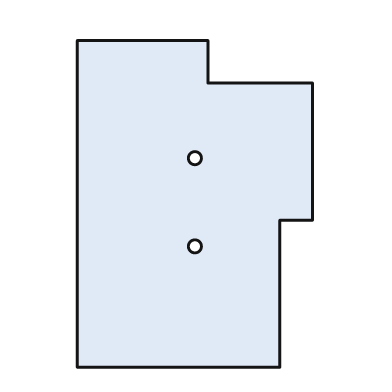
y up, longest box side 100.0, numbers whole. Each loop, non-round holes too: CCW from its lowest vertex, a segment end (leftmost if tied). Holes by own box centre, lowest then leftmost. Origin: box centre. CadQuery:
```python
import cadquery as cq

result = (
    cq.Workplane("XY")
    .moveTo(-36.0, -50.0)
    .lineTo(26.0, -50.0)
    .lineTo(26.0, -5.0)
    .lineTo(36.0, -5.0)
    .lineTo(36.0, 37.0)
    .lineTo(4.0, 37.0)
    .lineTo(4.0, 50.0)
    .lineTo(-36.0, 50.0)
    .close()
    .moveTo(0.0, -13.0)
    .circle(2.0)
    .moveTo(0.0, 14.0)
    .circle(2.0)
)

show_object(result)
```